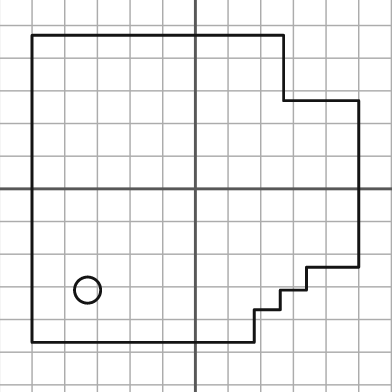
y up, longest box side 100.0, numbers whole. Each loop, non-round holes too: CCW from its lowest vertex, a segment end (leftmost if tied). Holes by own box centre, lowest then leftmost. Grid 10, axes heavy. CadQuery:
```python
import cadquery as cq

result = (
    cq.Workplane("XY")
    .moveTo(-50.0, -47.0)
    .lineTo(18.0, -47.0)
    .lineTo(18.0, -37.0)
    .lineTo(26.0, -37.0)
    .lineTo(26.0, -31.0)
    .lineTo(34.0, -31.0)
    .lineTo(34.0, -24.0)
    .lineTo(50.0, -24.0)
    .lineTo(50.0, 27.0)
    .lineTo(27.0, 27.0)
    .lineTo(27.0, 47.0)
    .lineTo(-50.0, 47.0)
    .close()
    .moveTo(-33.0, -31.0)
    .circle(4.0)
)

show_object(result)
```